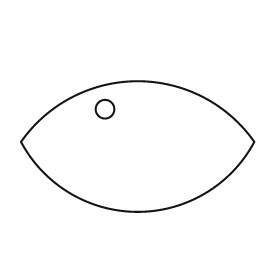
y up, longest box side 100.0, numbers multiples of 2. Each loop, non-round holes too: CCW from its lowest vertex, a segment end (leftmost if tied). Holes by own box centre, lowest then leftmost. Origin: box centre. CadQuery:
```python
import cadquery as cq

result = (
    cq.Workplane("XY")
    .moveTo(-50.0, 2.0)
    .threePointArc((0.0, -28.0), (50.0, 2.0))
    .threePointArc((0.0, 28.0), (-50.0, 2.0))
    .close()
    .moveTo(-14.0, 16.0)
    .circle(4.0)
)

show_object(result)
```